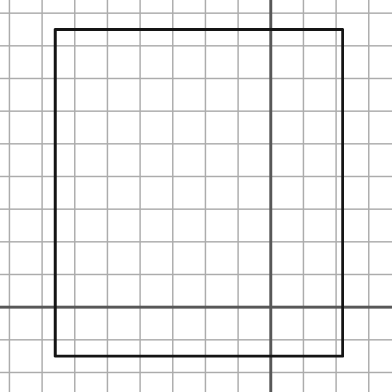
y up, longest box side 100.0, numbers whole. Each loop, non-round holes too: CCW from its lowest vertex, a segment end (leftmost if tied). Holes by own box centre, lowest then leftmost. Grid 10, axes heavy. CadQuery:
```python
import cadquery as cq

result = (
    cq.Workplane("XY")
    .moveTo(-66.0, -15.0)
    .lineTo(22.0, -15.0)
    .lineTo(22.0, 85.0)
    .lineTo(-66.0, 85.0)
    .close()
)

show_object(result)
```